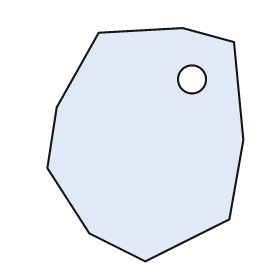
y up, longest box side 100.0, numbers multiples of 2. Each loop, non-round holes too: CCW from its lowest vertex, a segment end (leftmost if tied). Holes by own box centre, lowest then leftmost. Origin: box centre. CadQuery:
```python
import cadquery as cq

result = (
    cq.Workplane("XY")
    .moveTo(0.0, -50.0)
    .lineTo(36.0, -32.0)
    .lineTo(42.0, 2.0)
    .lineTo(38.0, 44.0)
    .lineTo(16.0, 50.0)
    .lineTo(-20.0, 48.0)
    .lineTo(-38.0, 16.0)
    .lineTo(-42.0, -10.0)
    .lineTo(-24.0, -38.0)
    .close()
    .moveTo(20.0, 28.0)
    .circle(6.0)
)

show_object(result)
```